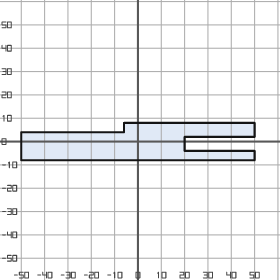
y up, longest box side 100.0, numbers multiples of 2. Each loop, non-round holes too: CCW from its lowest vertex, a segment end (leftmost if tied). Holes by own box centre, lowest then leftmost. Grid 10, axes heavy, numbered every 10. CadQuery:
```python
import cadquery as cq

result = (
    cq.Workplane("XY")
    .moveTo(-50.0, -8.0)
    .lineTo(50.0, -8.0)
    .lineTo(50.0, -4.0)
    .lineTo(20.0, -4.0)
    .lineTo(20.0, 2.0)
    .lineTo(50.0, 2.0)
    .lineTo(50.0, 8.0)
    .lineTo(-6.0, 8.0)
    .lineTo(-6.0, 4.0)
    .lineTo(-50.0, 4.0)
    .close()
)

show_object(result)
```